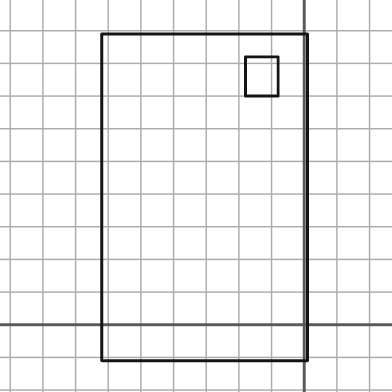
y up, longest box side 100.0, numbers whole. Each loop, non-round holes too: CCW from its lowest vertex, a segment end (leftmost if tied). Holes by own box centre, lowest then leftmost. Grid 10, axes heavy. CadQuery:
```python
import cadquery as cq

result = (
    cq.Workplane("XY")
    .moveTo(-62.0, -11.0)
    .lineTo(1.0, -11.0)
    .lineTo(1.0, 89.0)
    .lineTo(-62.0, 89.0)
    .close()
    .moveTo(-18.0, 70.0)
    .lineTo(-8.0, 70.0)
    .lineTo(-8.0, 82.0)
    .lineTo(-18.0, 82.0)
    .close()
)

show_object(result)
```